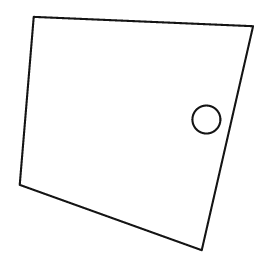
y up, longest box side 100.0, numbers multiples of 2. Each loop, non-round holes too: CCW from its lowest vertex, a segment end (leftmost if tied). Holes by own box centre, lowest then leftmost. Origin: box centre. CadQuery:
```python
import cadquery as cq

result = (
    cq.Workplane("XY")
    .moveTo(28.0, -50.0)
    .lineTo(50.0, 46.0)
    .lineTo(-44.0, 50.0)
    .lineTo(-50.0, -22.0)
    .close()
    .moveTo(30.0, 6.0)
    .circle(6.0)
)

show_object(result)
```